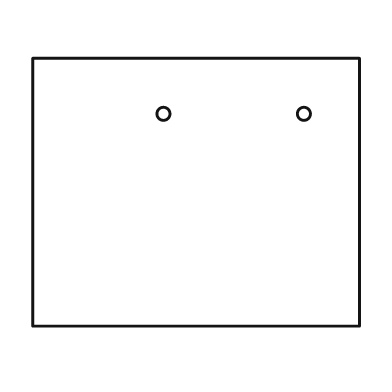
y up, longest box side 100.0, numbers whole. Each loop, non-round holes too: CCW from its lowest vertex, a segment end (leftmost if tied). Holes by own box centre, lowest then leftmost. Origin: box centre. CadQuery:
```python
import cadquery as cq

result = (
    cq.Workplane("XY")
    .moveTo(-50.0, -41.0)
    .lineTo(50.0, -41.0)
    .lineTo(50.0, 41.0)
    .lineTo(-50.0, 41.0)
    .close()
    .moveTo(-10.0, 24.0)
    .circle(2.0)
    .moveTo(33.0, 24.0)
    .circle(2.0)
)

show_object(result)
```